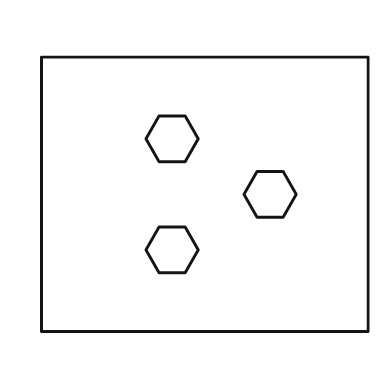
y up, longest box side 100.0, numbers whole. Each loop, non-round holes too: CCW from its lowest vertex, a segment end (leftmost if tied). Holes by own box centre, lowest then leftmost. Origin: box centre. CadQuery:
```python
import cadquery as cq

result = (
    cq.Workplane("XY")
    .moveTo(-50.0, -42.0)
    .lineTo(50.0, -42.0)
    .lineTo(50.0, 42.0)
    .lineTo(-50.0, 42.0)
    .close()
    .moveTo(-14.0, -24.0)
    .lineTo(-6.0, -24.0)
    .lineTo(-2.0, -17.0)
    .lineTo(-6.0, -10.0)
    .lineTo(-14.0, -10.0)
    .lineTo(-18.0, -17.0)
    .close()
    .moveTo(16.0, -7.0)
    .lineTo(24.0, -7.0)
    .lineTo(28.0, 0.0)
    .lineTo(24.0, 7.0)
    .lineTo(16.0, 7.0)
    .lineTo(12.0, 0.0)
    .close()
    .moveTo(-14.0, 10.0)
    .lineTo(-6.0, 10.0)
    .lineTo(-2.0, 17.0)
    .lineTo(-6.0, 24.0)
    .lineTo(-14.0, 24.0)
    .lineTo(-18.0, 17.0)
    .close()
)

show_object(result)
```